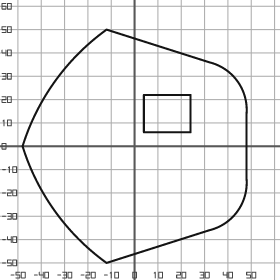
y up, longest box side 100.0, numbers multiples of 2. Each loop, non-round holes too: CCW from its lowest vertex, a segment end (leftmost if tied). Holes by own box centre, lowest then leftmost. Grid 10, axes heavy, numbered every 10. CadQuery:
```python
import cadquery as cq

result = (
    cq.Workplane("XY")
    .moveTo(-12.0, -50.0)
    .lineTo(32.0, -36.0)
    .threePointArc((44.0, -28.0), (48.0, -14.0))
    .lineTo(48.0, 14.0)
    .threePointArc((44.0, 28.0), (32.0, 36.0))
    .lineTo(-12.0, 50.0)
    .threePointArc((-34.0, 28.0), (-48.0, 0.0))
    .threePointArc((-34.0, -28.0), (-12.0, -50.0))
    .close()
    .moveTo(4.0, 6.0)
    .lineTo(24.0, 6.0)
    .lineTo(24.0, 22.0)
    .lineTo(4.0, 22.0)
    .close()
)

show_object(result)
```